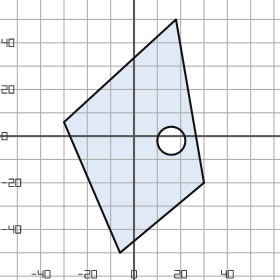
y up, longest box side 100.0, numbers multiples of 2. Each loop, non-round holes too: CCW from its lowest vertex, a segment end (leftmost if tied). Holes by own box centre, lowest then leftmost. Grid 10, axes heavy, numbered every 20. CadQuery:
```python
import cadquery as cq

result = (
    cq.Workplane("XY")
    .moveTo(-6.0, -50.0)
    .lineTo(30.0, -20.0)
    .lineTo(18.0, 50.0)
    .lineTo(-30.0, 6.0)
    .close()
    .moveTo(16.0, -2.0)
    .circle(6.0)
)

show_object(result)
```